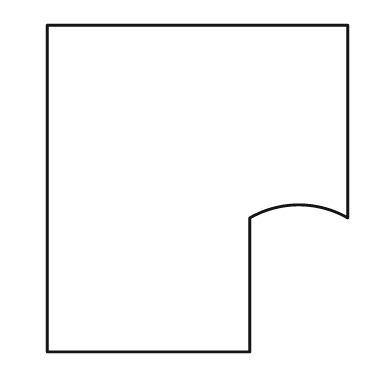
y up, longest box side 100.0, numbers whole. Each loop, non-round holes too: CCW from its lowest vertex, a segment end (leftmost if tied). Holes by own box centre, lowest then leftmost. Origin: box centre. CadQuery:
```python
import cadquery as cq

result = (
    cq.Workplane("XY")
    .moveTo(-46.0, -50.0)
    .lineTo(16.0, -50.0)
    .lineTo(16.0, -9.0)
    .threePointArc((31.0, -5.0), (46.0, -9.0))
    .lineTo(46.0, 50.0)
    .lineTo(-46.0, 50.0)
    .close()
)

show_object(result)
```